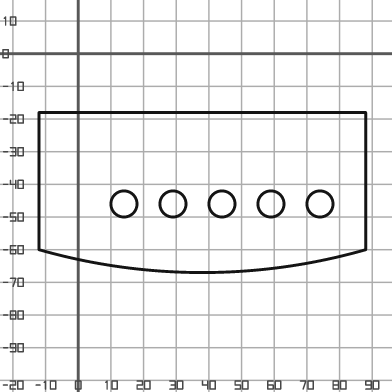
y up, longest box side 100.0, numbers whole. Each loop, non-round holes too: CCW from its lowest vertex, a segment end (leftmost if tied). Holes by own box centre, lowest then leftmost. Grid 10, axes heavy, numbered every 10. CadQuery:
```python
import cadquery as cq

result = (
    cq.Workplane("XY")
    .moveTo(-12.0, -60.0)
    .threePointArc((38.0, -67.0), (88.0, -60.0))
    .lineTo(88.0, -18.0)
    .lineTo(-12.0, -18.0)
    .close()
    .moveTo(14.0, -46.0)
    .circle(4.0)
    .moveTo(29.0, -46.0)
    .circle(4.0)
    .moveTo(44.0, -46.0)
    .circle(4.0)
    .moveTo(59.0, -46.0)
    .circle(4.0)
    .moveTo(74.0, -46.0)
    .circle(4.0)
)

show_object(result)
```